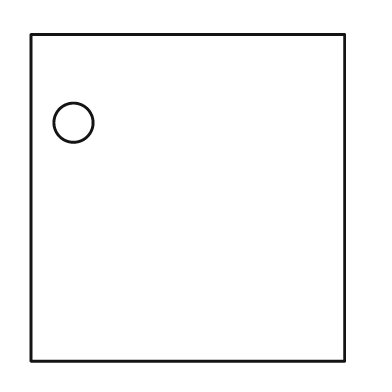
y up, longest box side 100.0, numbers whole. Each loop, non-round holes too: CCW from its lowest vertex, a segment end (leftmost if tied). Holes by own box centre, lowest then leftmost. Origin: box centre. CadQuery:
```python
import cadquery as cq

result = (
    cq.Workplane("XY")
    .moveTo(-48.0, -50.0)
    .lineTo(48.0, -50.0)
    .lineTo(48.0, 50.0)
    .lineTo(-48.0, 50.0)
    .close()
    .moveTo(-35.0, 23.0)
    .circle(6.0)
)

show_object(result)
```